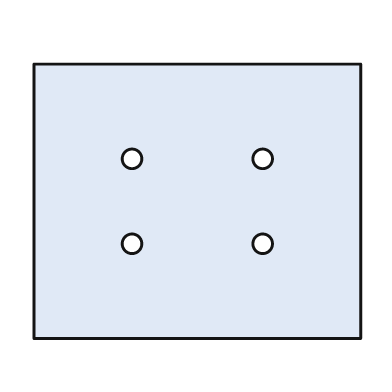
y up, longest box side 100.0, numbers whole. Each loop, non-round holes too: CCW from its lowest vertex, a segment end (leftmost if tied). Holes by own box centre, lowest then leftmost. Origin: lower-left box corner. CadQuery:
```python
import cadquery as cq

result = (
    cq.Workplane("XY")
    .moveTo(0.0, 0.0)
    .lineTo(100.0, 0.0)
    .lineTo(100.0, 84.0)
    .lineTo(0.0, 84.0)
    .close()
    .moveTo(30.0, 29.0)
    .circle(3.0)
    .moveTo(70.0, 29.0)
    .circle(3.0)
    .moveTo(30.0, 55.0)
    .circle(3.0)
    .moveTo(70.0, 55.0)
    .circle(3.0)
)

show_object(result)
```